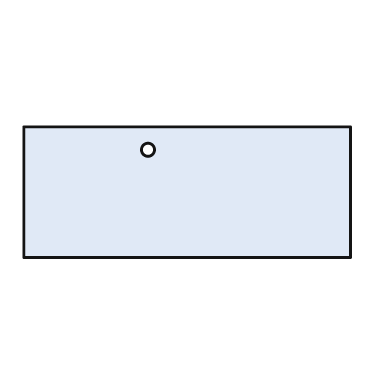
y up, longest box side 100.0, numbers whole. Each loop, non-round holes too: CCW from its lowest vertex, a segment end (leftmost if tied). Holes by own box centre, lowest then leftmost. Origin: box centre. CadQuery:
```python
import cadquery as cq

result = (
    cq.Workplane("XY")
    .moveTo(-50.0, -20.0)
    .lineTo(50.0, -20.0)
    .lineTo(50.0, 20.0)
    .lineTo(-50.0, 20.0)
    .close()
    .moveTo(-12.0, 13.0)
    .circle(2.0)
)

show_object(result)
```